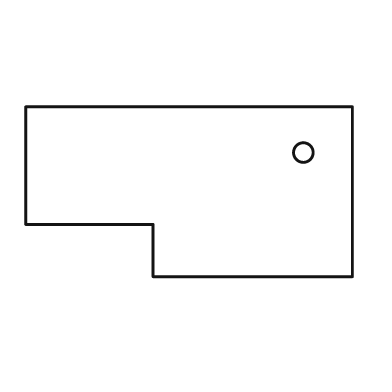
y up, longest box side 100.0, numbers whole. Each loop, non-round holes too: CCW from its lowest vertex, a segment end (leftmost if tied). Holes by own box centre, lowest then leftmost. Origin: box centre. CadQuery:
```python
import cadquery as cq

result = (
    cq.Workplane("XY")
    .moveTo(-11.0, -26.0)
    .lineTo(50.0, -26.0)
    .lineTo(50.0, 26.0)
    .lineTo(-50.0, 26.0)
    .lineTo(-50.0, -10.0)
    .lineTo(-11.0, -10.0)
    .close()
    .moveTo(35.0, 12.0)
    .circle(3.0)
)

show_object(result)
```